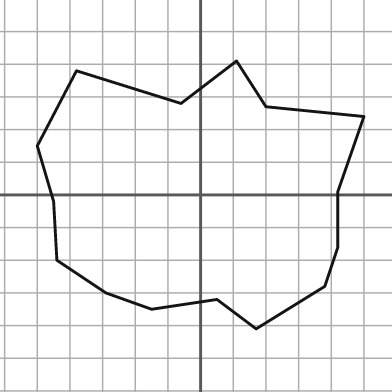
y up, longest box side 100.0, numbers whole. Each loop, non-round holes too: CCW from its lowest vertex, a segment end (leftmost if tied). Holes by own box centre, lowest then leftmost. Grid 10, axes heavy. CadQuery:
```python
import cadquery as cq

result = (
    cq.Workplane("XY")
    .moveTo(17.0, -41.0)
    .lineTo(38.0, -28.0)
    .lineTo(42.0, -16.0)
    .lineTo(42.0, 1.0)
    .lineTo(50.0, 24.0)
    .lineTo(20.0, 27.0)
    .lineTo(11.0, 41.0)
    .lineTo(-6.0, 28.0)
    .lineTo(-38.0, 38.0)
    .lineTo(-50.0, 15.0)
    .lineTo(-45.0, -2.0)
    .lineTo(-44.0, -20.0)
    .lineTo(-29.0, -30.0)
    .lineTo(-15.0, -35.0)
    .lineTo(5.0, -32.0)
    .close()
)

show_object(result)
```